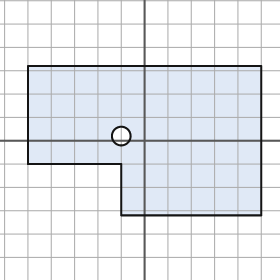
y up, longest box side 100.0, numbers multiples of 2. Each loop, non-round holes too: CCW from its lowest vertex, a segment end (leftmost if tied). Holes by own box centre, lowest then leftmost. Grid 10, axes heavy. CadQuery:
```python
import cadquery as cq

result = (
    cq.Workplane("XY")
    .moveTo(-10.0, -32.0)
    .lineTo(50.0, -32.0)
    .lineTo(50.0, 32.0)
    .lineTo(-50.0, 32.0)
    .lineTo(-50.0, -10.0)
    .lineTo(-10.0, -10.0)
    .close()
    .moveTo(-10.0, 2.0)
    .circle(4.0)
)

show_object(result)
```